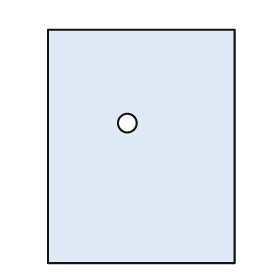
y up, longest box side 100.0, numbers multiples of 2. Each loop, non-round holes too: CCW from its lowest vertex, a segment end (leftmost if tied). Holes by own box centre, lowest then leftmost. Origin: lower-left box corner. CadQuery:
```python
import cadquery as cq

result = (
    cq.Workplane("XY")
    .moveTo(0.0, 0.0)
    .lineTo(80.0, 0.0)
    .lineTo(80.0, 100.0)
    .lineTo(0.0, 100.0)
    .close()
    .moveTo(34.0, 60.0)
    .circle(4.0)
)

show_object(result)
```